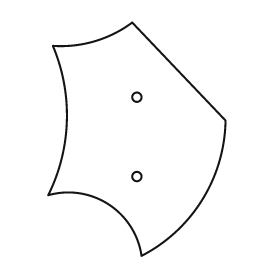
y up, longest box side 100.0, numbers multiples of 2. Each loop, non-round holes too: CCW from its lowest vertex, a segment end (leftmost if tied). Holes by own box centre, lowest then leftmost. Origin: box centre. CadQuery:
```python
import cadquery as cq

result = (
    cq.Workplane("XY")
    .moveTo(2.0, -50.0)
    .threePointArc((28.0, -26.0), (38.0, 8.0))
    .lineTo(-2.0, 50.0)
    .threePointArc((-18.0, 42.0), (-36.0, 40.0))
    .threePointArc((-30.0, 8.0), (-38.0, -24.0))
    .threePointArc((-12.0, -28.0), (2.0, -50.0))
    .close()
    .moveTo(0.0, -16.0)
    .circle(2.0)
    .moveTo(0.0, 18.0)
    .circle(2.0)
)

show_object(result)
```